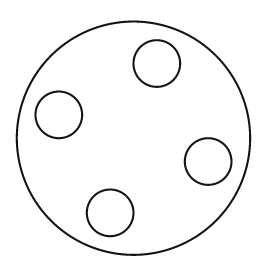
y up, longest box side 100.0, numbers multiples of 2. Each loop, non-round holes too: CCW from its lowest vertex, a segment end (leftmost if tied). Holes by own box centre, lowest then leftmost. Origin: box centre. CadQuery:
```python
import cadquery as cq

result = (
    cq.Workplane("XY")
    .moveTo(0.0, 0.0)
    .circle(50.0)
    .moveTo(-10.0, -32.0)
    .circle(10.0)
    .moveTo(32.0, -10.0)
    .circle(10.0)
    .moveTo(-32.0, 10.0)
    .circle(10.0)
    .moveTo(10.0, 32.0)
    .circle(10.0)
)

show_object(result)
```